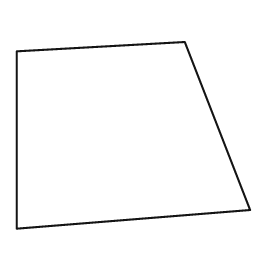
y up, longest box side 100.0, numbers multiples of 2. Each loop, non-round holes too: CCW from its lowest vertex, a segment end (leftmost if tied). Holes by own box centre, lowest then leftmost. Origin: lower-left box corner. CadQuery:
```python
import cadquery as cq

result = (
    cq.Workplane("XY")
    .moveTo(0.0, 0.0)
    .lineTo(100.0, 8.0)
    .lineTo(72.0, 80.0)
    .lineTo(0.0, 76.0)
    .close()
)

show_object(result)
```